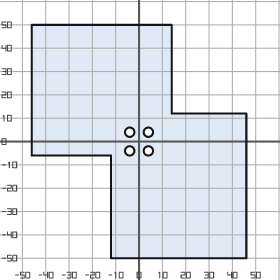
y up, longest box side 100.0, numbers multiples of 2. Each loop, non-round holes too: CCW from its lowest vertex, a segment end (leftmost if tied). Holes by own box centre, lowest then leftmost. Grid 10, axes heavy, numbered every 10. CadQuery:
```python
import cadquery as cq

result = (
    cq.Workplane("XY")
    .moveTo(-12.0, -50.0)
    .lineTo(46.0, -50.0)
    .lineTo(46.0, 12.0)
    .lineTo(14.0, 12.0)
    .lineTo(14.0, 50.0)
    .lineTo(-46.0, 50.0)
    .lineTo(-46.0, -6.0)
    .lineTo(-12.0, -6.0)
    .close()
    .moveTo(-4.0, -4.0)
    .circle(2.0)
    .moveTo(4.0, -4.0)
    .circle(2.0)
    .moveTo(-4.0, 4.0)
    .circle(2.0)
    .moveTo(4.0, 4.0)
    .circle(2.0)
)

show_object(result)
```